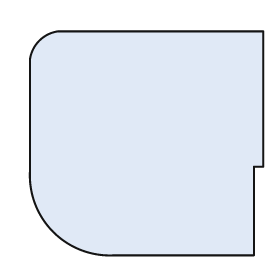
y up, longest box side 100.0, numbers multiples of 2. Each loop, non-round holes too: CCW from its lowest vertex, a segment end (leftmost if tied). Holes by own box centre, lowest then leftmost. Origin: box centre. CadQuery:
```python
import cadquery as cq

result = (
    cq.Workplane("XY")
    .moveTo(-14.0, -48.0)
    .lineTo(46.0, -48.0)
    .lineTo(46.0, -10.0)
    .lineTo(50.0, -10.0)
    .lineTo(50.0, 48.0)
    .lineTo(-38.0, 48.0)
    .threePointArc((-46.0, 44.0), (-50.0, 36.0))
    .lineTo(-50.0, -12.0)
    .threePointArc((-40.0, -38.0), (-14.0, -48.0))
    .close()
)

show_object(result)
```